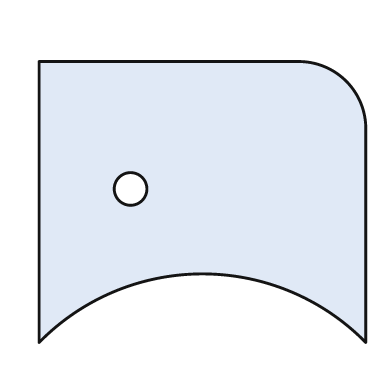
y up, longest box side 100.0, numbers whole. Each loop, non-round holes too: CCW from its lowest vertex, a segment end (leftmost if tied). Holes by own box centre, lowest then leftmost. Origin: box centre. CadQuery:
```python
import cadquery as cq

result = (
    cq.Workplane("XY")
    .moveTo(-50.0, -43.0)
    .threePointArc((0.0, -22.0), (50.0, -43.0))
    .lineTo(50.0, 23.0)
    .threePointArc((44.0, 37.0), (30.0, 43.0))
    .lineTo(-50.0, 43.0)
    .close()
    .moveTo(-22.0, 4.0)
    .circle(5.0)
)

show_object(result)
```